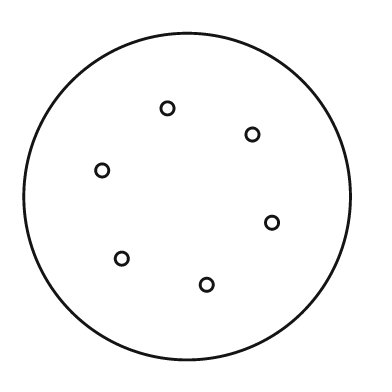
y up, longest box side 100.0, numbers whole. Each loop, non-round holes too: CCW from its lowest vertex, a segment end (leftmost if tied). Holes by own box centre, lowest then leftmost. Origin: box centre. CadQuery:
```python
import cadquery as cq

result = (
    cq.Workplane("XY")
    .moveTo(0.0, 0.0)
    .circle(50.0)
    .moveTo(6.0, -27.0)
    .circle(2.0)
    .moveTo(-20.0, -19.0)
    .circle(2.0)
    .moveTo(26.0, -8.0)
    .circle(2.0)
    .moveTo(-26.0, 8.0)
    .circle(2.0)
    .moveTo(20.0, 19.0)
    .circle(2.0)
    .moveTo(-6.0, 27.0)
    .circle(2.0)
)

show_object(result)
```